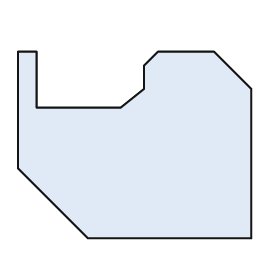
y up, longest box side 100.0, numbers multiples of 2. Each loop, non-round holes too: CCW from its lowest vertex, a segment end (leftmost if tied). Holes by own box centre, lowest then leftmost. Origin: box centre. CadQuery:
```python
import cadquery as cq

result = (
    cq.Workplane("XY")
    .moveTo(-20.0, -40.0)
    .lineTo(50.0, -40.0)
    .lineTo(50.0, 24.0)
    .lineTo(34.0, 40.0)
    .lineTo(10.0, 40.0)
    .lineTo(4.0, 34.0)
    .lineTo(4.0, 24.0)
    .lineTo(-6.0, 16.0)
    .lineTo(-42.0, 16.0)
    .lineTo(-42.0, 40.0)
    .lineTo(-50.0, 40.0)
    .lineTo(-50.0, -10.0)
    .close()
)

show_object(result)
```